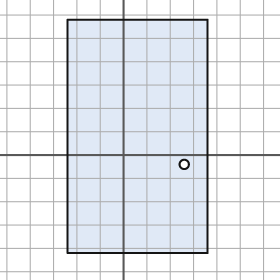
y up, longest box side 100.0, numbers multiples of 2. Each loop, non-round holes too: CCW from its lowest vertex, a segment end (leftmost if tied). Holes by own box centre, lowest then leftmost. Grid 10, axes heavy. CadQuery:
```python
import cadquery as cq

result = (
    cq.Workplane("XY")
    .moveTo(-24.0, -42.0)
    .lineTo(36.0, -42.0)
    .lineTo(36.0, 58.0)
    .lineTo(-24.0, 58.0)
    .close()
    .moveTo(26.0, -4.0)
    .circle(2.0)
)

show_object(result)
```